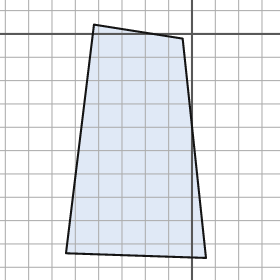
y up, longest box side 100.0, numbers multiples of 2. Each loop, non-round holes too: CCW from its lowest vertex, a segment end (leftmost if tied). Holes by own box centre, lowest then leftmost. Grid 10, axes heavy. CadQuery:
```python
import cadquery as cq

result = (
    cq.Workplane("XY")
    .moveTo(6.0, -96.0)
    .lineTo(-4.0, -2.0)
    .lineTo(-42.0, 4.0)
    .lineTo(-54.0, -94.0)
    .close()
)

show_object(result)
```